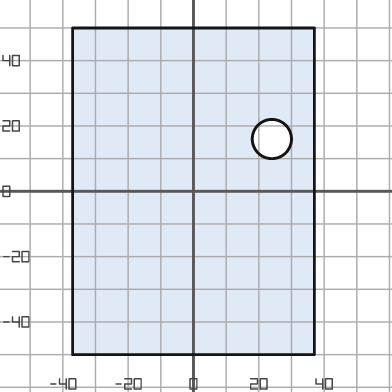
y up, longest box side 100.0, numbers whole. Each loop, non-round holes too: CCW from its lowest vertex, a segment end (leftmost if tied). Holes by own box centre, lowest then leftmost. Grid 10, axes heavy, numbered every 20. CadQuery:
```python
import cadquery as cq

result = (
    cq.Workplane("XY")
    .moveTo(-37.0, -50.0)
    .lineTo(37.0, -50.0)
    .lineTo(37.0, 50.0)
    .lineTo(-37.0, 50.0)
    .close()
    .moveTo(24.0, 16.0)
    .circle(6.0)
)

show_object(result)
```